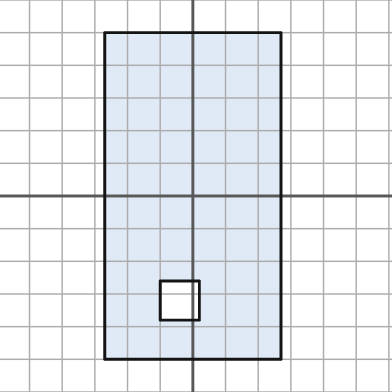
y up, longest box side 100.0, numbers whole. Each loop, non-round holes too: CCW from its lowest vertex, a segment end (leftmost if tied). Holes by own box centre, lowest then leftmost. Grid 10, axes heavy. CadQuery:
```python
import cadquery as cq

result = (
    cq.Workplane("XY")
    .moveTo(-27.0, -50.0)
    .lineTo(27.0, -50.0)
    .lineTo(27.0, 50.0)
    .lineTo(-27.0, 50.0)
    .close()
    .moveTo(-10.0, -38.0)
    .lineTo(2.0, -38.0)
    .lineTo(2.0, -26.0)
    .lineTo(-10.0, -26.0)
    .close()
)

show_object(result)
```